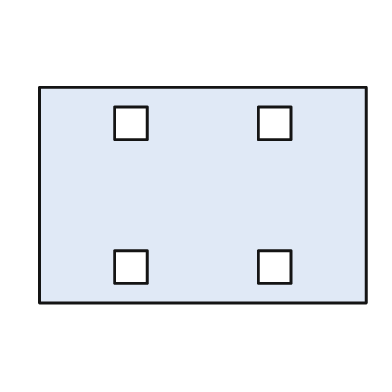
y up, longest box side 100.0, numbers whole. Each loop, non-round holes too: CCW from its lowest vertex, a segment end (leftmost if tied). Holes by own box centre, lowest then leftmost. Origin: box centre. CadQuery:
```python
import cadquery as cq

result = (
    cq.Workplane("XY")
    .moveTo(-50.0, -33.0)
    .lineTo(50.0, -33.0)
    .lineTo(50.0, 33.0)
    .lineTo(-50.0, 33.0)
    .close()
    .moveTo(-27.0, -27.0)
    .lineTo(-17.0, -27.0)
    .lineTo(-17.0, -17.0)
    .lineTo(-27.0, -17.0)
    .close()
    .moveTo(17.0, -27.0)
    .lineTo(27.0, -27.0)
    .lineTo(27.0, -17.0)
    .lineTo(17.0, -17.0)
    .close()
    .moveTo(-27.0, 17.0)
    .lineTo(-17.0, 17.0)
    .lineTo(-17.0, 27.0)
    .lineTo(-27.0, 27.0)
    .close()
    .moveTo(17.0, 17.0)
    .lineTo(27.0, 17.0)
    .lineTo(27.0, 27.0)
    .lineTo(17.0, 27.0)
    .close()
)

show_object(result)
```